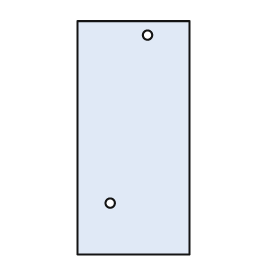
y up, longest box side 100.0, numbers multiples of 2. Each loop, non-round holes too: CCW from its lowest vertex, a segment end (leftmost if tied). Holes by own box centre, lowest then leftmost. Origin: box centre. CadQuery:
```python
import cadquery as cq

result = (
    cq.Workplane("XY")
    .moveTo(-24.0, -50.0)
    .lineTo(24.0, -50.0)
    .lineTo(24.0, 50.0)
    .lineTo(-24.0, 50.0)
    .close()
    .moveTo(-10.0, -28.0)
    .circle(2.0)
    .moveTo(6.0, 44.0)
    .circle(2.0)
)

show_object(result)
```